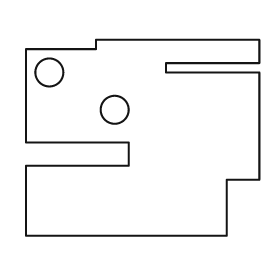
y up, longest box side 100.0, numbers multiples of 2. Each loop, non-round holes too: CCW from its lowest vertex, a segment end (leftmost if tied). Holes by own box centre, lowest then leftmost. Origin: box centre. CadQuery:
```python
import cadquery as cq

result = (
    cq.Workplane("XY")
    .moveTo(-50.0, -42.0)
    .lineTo(36.0, -42.0)
    .lineTo(36.0, -18.0)
    .lineTo(50.0, -18.0)
    .lineTo(50.0, 28.0)
    .lineTo(10.0, 28.0)
    .lineTo(10.0, 32.0)
    .lineTo(50.0, 32.0)
    .lineTo(50.0, 42.0)
    .lineTo(-20.0, 42.0)
    .lineTo(-20.0, 38.0)
    .lineTo(-50.0, 38.0)
    .lineTo(-50.0, -2.0)
    .lineTo(-6.0, -2.0)
    .lineTo(-6.0, -12.0)
    .lineTo(-50.0, -12.0)
    .close()
    .moveTo(-12.0, 12.0)
    .circle(6.0)
    .moveTo(-40.0, 28.0)
    .circle(6.0)
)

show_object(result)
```